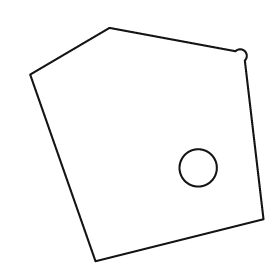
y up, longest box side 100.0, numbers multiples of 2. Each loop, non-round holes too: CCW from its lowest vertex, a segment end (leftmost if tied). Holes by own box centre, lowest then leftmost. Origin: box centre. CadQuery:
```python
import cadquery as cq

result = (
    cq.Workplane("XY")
    .moveTo(-22.0, -50.0)
    .lineTo(50.0, -32.0)
    .lineTo(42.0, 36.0)
    .threePointArc((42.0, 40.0), (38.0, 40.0))
    .lineTo(-16.0, 50.0)
    .lineTo(-50.0, 30.0)
    .close()
    .moveTo(22.0, -10.0)
    .circle(8.0)
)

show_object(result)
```